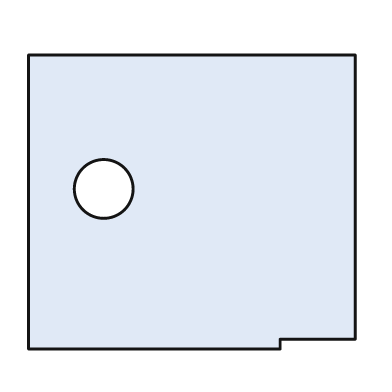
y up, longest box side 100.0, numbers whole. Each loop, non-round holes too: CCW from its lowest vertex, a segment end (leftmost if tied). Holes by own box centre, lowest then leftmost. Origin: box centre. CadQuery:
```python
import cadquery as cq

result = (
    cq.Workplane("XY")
    .moveTo(-50.0, -45.0)
    .lineTo(27.0, -45.0)
    .lineTo(27.0, -42.0)
    .lineTo(50.0, -42.0)
    .lineTo(50.0, 45.0)
    .lineTo(-50.0, 45.0)
    .close()
    .moveTo(-27.0, 4.0)
    .circle(9.0)
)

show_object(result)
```